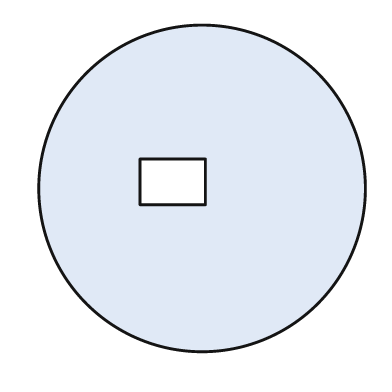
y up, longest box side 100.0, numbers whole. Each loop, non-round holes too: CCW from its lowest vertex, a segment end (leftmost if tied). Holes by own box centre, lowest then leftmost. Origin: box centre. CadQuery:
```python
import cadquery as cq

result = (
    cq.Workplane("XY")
    .moveTo(0.0, 0.0)
    .circle(50.0)
    .moveTo(-19.0, -5.0)
    .lineTo(1.0, -5.0)
    .lineTo(1.0, 9.0)
    .lineTo(-19.0, 9.0)
    .close()
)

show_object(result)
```